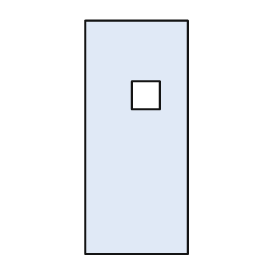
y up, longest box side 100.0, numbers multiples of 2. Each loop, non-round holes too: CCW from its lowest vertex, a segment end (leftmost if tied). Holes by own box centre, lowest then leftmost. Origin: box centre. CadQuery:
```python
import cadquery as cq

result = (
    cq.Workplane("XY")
    .moveTo(-22.0, -50.0)
    .lineTo(22.0, -50.0)
    .lineTo(22.0, 50.0)
    .lineTo(-22.0, 50.0)
    .close()
    .moveTo(-2.0, 12.0)
    .lineTo(10.0, 12.0)
    .lineTo(10.0, 24.0)
    .lineTo(-2.0, 24.0)
    .close()
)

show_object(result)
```